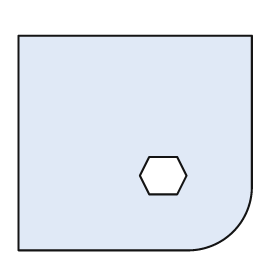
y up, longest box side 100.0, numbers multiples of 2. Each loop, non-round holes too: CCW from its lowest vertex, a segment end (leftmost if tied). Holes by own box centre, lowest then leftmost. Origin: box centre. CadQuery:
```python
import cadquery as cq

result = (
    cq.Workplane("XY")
    .moveTo(-50.0, -46.0)
    .lineTo(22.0, -46.0)
    .threePointArc((42.0, -38.0), (50.0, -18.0))
    .lineTo(50.0, 46.0)
    .lineTo(-50.0, 46.0)
    .close()
    .moveTo(6.0, -22.0)
    .lineTo(18.0, -22.0)
    .lineTo(22.0, -14.0)
    .lineTo(18.0, -6.0)
    .lineTo(6.0, -6.0)
    .lineTo(2.0, -14.0)
    .close()
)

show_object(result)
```